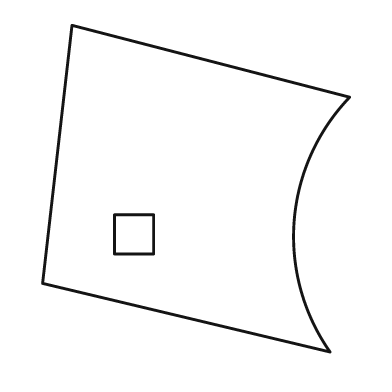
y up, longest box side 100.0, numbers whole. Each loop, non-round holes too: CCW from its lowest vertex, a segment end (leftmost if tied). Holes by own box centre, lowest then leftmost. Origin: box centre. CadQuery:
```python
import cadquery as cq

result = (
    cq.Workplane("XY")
    .moveTo(41.0, -50.0)
    .threePointArc((30.0, -10.0), (47.0, 28.0))
    .lineTo(-38.0, 50.0)
    .lineTo(-47.0, -29.0)
    .close()
    .moveTo(-25.0, -20.0)
    .lineTo(-13.0, -20.0)
    .lineTo(-13.0, -8.0)
    .lineTo(-25.0, -8.0)
    .close()
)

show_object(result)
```